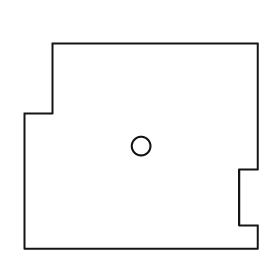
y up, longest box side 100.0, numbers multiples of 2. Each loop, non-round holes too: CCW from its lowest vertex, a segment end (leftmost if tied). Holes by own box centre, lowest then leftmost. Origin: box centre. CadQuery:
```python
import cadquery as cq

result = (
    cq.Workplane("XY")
    .moveTo(-50.0, -44.0)
    .lineTo(50.0, -44.0)
    .lineTo(50.0, -34.0)
    .lineTo(42.0, -34.0)
    .lineTo(42.0, -10.0)
    .lineTo(50.0, -10.0)
    .lineTo(50.0, 44.0)
    .lineTo(-38.0, 44.0)
    .lineTo(-38.0, 14.0)
    .lineTo(-50.0, 14.0)
    .close()
    .moveTo(0.0, 0.0)
    .circle(4.0)
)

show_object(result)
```